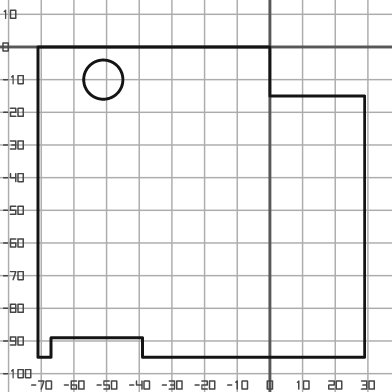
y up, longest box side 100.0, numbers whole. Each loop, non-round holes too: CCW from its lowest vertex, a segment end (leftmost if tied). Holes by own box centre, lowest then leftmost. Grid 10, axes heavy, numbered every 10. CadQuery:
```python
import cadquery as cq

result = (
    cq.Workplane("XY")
    .moveTo(-71.0, -95.0)
    .lineTo(-67.0, -95.0)
    .lineTo(-67.0, -89.0)
    .lineTo(-39.0, -89.0)
    .lineTo(-39.0, -95.0)
    .lineTo(29.0, -95.0)
    .lineTo(29.0, -15.0)
    .lineTo(0.0, -15.0)
    .lineTo(0.0, 0.0)
    .lineTo(-71.0, 0.0)
    .close()
    .moveTo(-51.0, -10.0)
    .circle(6.0)
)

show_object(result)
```